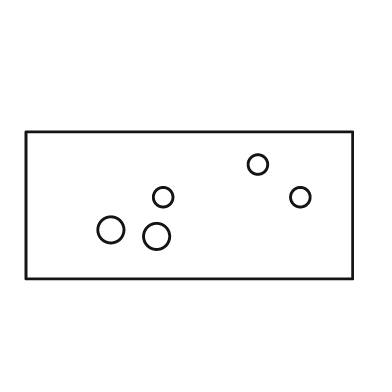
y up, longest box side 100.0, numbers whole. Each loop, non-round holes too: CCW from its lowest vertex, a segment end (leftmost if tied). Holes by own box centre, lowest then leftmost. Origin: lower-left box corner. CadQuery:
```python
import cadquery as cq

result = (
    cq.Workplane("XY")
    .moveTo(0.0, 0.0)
    .lineTo(100.0, 0.0)
    .lineTo(100.0, 45.0)
    .lineTo(0.0, 45.0)
    .close()
    .moveTo(40.0, 13.0)
    .circle(4.0)
    .moveTo(26.0, 15.0)
    .circle(4.0)
    .moveTo(42.0, 25.0)
    .circle(3.0)
    .moveTo(84.0, 25.0)
    .circle(3.0)
    .moveTo(71.0, 35.0)
    .circle(3.0)
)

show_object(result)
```